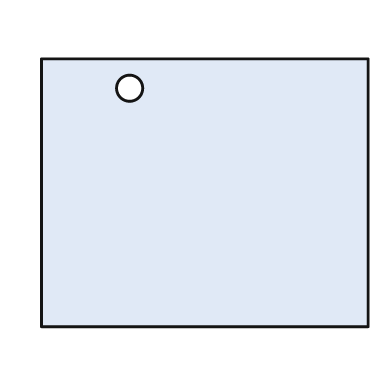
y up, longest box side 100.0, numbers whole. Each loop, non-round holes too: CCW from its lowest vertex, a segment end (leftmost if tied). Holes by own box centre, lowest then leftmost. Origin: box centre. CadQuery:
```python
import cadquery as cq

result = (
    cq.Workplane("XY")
    .moveTo(-50.0, -41.0)
    .lineTo(50.0, -41.0)
    .lineTo(50.0, 41.0)
    .lineTo(-50.0, 41.0)
    .close()
    .moveTo(-23.0, 32.0)
    .circle(4.0)
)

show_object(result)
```